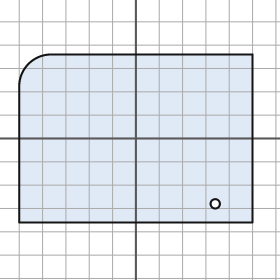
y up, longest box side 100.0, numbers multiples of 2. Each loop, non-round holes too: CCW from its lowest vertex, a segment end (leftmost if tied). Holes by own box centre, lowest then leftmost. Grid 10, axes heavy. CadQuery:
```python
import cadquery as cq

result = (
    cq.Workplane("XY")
    .moveTo(-50.0, -36.0)
    .lineTo(50.0, -36.0)
    .lineTo(50.0, 36.0)
    .lineTo(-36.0, 36.0)
    .threePointArc((-46.0, 32.0), (-50.0, 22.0))
    .close()
    .moveTo(34.0, -28.0)
    .circle(2.0)
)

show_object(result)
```